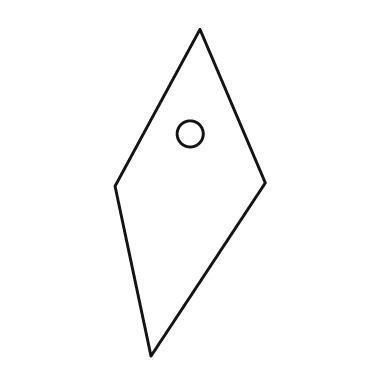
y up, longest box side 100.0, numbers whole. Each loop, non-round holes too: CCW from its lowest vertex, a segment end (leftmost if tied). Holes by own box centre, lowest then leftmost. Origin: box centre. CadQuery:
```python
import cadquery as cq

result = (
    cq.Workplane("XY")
    .moveTo(-12.0, -50.0)
    .lineTo(23.0, 3.0)
    .lineTo(3.0, 50.0)
    .lineTo(-23.0, 2.0)
    .close()
    .moveTo(0.0, 18.0)
    .circle(4.0)
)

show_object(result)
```